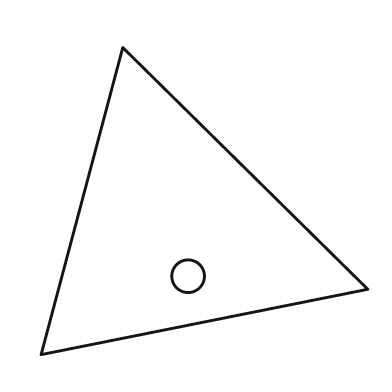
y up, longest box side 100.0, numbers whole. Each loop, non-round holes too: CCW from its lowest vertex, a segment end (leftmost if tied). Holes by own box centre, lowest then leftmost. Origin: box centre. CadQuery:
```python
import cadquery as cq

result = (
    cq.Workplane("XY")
    .moveTo(-50.0, -47.0)
    .lineTo(50.0, -27.0)
    .lineTo(-25.0, 47.0)
    .close()
    .moveTo(-5.0, -23.0)
    .circle(5.0)
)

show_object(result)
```